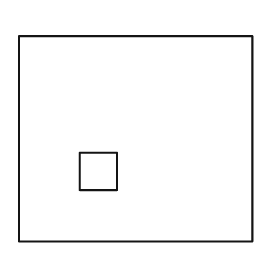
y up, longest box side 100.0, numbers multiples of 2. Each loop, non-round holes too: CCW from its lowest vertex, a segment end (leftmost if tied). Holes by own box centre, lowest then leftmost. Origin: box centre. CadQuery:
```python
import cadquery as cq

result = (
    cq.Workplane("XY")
    .moveTo(-50.0, -44.0)
    .lineTo(50.0, -44.0)
    .lineTo(50.0, 44.0)
    .lineTo(-50.0, 44.0)
    .close()
    .moveTo(-24.0, -22.0)
    .lineTo(-8.0, -22.0)
    .lineTo(-8.0, -6.0)
    .lineTo(-24.0, -6.0)
    .close()
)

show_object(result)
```